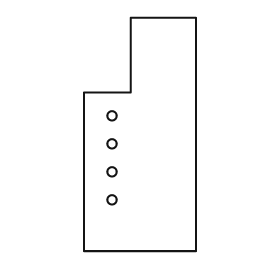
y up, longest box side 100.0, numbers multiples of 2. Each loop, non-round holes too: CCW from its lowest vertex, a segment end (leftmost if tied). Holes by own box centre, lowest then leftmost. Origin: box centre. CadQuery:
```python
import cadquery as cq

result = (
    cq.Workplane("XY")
    .moveTo(-24.0, -50.0)
    .lineTo(24.0, -50.0)
    .lineTo(24.0, 50.0)
    .lineTo(-4.0, 50.0)
    .lineTo(-4.0, 18.0)
    .lineTo(-24.0, 18.0)
    .close()
    .moveTo(-12.0, -28.0)
    .circle(2.0)
    .moveTo(-12.0, -16.0)
    .circle(2.0)
    .moveTo(-12.0, -4.0)
    .circle(2.0)
    .moveTo(-12.0, 8.0)
    .circle(2.0)
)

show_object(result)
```